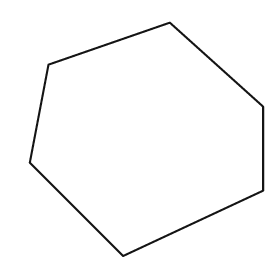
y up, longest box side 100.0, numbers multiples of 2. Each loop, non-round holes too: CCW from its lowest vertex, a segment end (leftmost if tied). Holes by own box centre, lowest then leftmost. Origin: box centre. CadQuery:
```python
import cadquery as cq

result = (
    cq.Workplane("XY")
    .moveTo(-10.0, -50.0)
    .lineTo(50.0, -22.0)
    .lineTo(50.0, 14.0)
    .lineTo(10.0, 50.0)
    .lineTo(-42.0, 32.0)
    .lineTo(-50.0, -10.0)
    .close()
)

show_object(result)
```